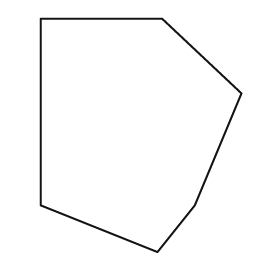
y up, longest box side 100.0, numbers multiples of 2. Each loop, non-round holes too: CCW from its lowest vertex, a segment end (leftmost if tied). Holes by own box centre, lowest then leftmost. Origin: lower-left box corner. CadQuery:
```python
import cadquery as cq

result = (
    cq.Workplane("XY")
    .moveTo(50.0, 0.0)
    .lineTo(66.0, 20.0)
    .lineTo(86.0, 68.0)
    .lineTo(52.0, 100.0)
    .lineTo(0.0, 100.0)
    .lineTo(0.0, 20.0)
    .close()
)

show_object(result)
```